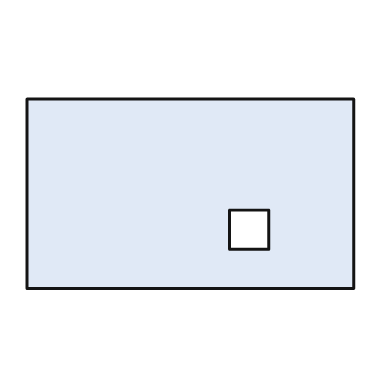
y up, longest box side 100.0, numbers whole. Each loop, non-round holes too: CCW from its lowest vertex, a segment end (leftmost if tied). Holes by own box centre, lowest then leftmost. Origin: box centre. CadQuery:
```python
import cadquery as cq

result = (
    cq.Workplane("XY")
    .moveTo(-50.0, -29.0)
    .lineTo(50.0, -29.0)
    .lineTo(50.0, 29.0)
    .lineTo(-50.0, 29.0)
    .close()
    .moveTo(12.0, -17.0)
    .lineTo(24.0, -17.0)
    .lineTo(24.0, -5.0)
    .lineTo(12.0, -5.0)
    .close()
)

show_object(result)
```